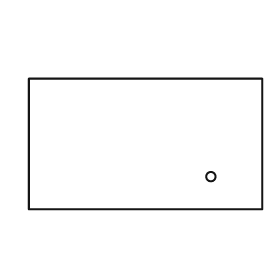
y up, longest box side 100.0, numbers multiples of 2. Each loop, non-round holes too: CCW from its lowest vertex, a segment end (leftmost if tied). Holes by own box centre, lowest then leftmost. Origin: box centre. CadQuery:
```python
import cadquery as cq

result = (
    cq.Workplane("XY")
    .moveTo(-50.0, -28.0)
    .lineTo(50.0, -28.0)
    .lineTo(50.0, 28.0)
    .lineTo(-50.0, 28.0)
    .close()
    .moveTo(28.0, -14.0)
    .circle(2.0)
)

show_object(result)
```